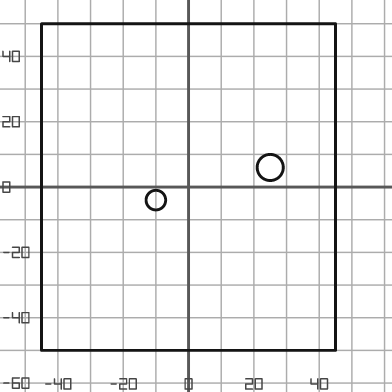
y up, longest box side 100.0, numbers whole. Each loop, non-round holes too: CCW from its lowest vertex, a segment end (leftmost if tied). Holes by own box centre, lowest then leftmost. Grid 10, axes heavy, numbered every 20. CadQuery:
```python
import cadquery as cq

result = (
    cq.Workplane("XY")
    .moveTo(-45.0, -50.0)
    .lineTo(45.0, -50.0)
    .lineTo(45.0, 50.0)
    .lineTo(-45.0, 50.0)
    .close()
    .moveTo(-10.0, -4.0)
    .circle(3.0)
    .moveTo(25.0, 6.0)
    .circle(4.0)
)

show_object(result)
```